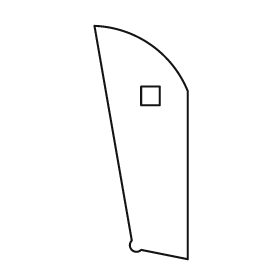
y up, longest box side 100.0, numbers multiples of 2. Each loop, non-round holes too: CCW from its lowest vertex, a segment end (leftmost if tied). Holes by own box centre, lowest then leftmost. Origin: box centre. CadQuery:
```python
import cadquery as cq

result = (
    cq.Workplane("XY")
    .moveTo(20.0, -50.0)
    .lineTo(20.0, 22.0)
    .threePointArc((4.0, 42.0), (-20.0, 50.0))
    .lineTo(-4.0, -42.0)
    .threePointArc((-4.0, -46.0), (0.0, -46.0))
    .close()
    .moveTo(0.0, 16.0)
    .lineTo(8.0, 16.0)
    .lineTo(8.0, 24.0)
    .lineTo(0.0, 24.0)
    .close()
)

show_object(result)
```